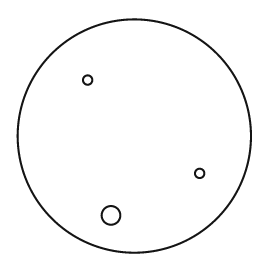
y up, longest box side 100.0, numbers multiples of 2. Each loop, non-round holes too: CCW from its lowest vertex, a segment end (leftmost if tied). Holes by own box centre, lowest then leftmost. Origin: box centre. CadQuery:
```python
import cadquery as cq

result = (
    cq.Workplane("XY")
    .moveTo(0.0, 0.0)
    .circle(50.0)
    .moveTo(-10.0, -34.0)
    .circle(4.0)
    .moveTo(28.0, -16.0)
    .circle(2.0)
    .moveTo(-20.0, 24.0)
    .circle(2.0)
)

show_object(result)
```